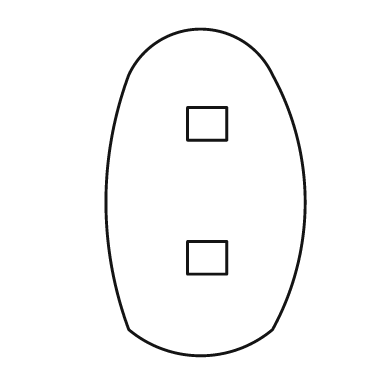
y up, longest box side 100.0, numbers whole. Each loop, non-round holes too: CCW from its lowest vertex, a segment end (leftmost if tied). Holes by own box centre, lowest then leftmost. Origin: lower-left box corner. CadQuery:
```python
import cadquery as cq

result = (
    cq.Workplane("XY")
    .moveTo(7.0, 8.0)
    .threePointArc((29.0, 0.0), (51.0, 8.0))
    .threePointArc((61.0, 47.0), (51.0, 86.0))
    .threePointArc((29.0, 100.0), (7.0, 86.0))
    .threePointArc((0.0, 47.0), (7.0, 8.0))
    .close()
    .moveTo(25.0, 25.0)
    .lineTo(37.0, 25.0)
    .lineTo(37.0, 35.0)
    .lineTo(25.0, 35.0)
    .close()
    .moveTo(25.0, 66.0)
    .lineTo(37.0, 66.0)
    .lineTo(37.0, 76.0)
    .lineTo(25.0, 76.0)
    .close()
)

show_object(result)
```